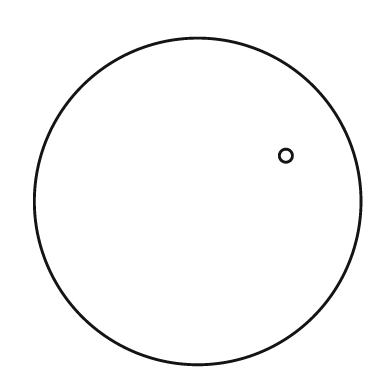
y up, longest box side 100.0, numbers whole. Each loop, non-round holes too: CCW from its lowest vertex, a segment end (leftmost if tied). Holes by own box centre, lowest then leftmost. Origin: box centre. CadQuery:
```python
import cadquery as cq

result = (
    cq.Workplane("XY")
    .moveTo(0.0, 0.0)
    .circle(50.0)
    .moveTo(27.0, 14.0)
    .circle(2.0)
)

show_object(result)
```